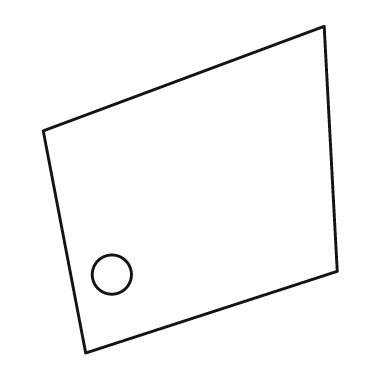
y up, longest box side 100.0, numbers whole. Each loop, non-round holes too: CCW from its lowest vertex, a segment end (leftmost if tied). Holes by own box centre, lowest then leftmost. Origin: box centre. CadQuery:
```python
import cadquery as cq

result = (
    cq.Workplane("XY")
    .moveTo(-32.0, -50.0)
    .lineTo(45.0, -25.0)
    .lineTo(41.0, 50.0)
    .lineTo(-45.0, 18.0)
    .close()
    .moveTo(-24.0, -26.0)
    .circle(6.0)
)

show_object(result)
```